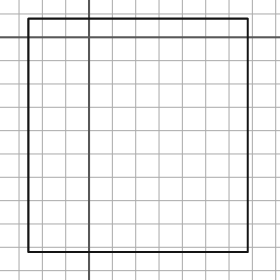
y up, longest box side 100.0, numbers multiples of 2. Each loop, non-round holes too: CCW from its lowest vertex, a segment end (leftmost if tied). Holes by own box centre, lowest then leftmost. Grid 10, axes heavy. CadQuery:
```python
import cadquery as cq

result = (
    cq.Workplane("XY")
    .moveTo(-26.0, -92.0)
    .lineTo(68.0, -92.0)
    .lineTo(68.0, 8.0)
    .lineTo(-26.0, 8.0)
    .close()
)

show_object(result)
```